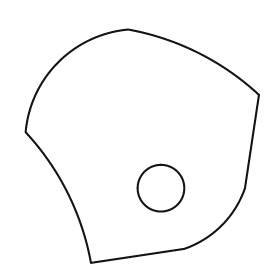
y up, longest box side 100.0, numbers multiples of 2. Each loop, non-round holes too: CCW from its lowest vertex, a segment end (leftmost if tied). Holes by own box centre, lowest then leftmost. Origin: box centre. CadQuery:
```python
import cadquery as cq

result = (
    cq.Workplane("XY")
    .moveTo(-22.0, -50.0)
    .lineTo(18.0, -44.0)
    .threePointArc((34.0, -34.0), (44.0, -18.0))
    .lineTo(50.0, 22.0)
    .threePointArc((24.0, 40.0), (-6.0, 50.0))
    .threePointArc((-36.0, 36.0), (-50.0, 6.0))
    .threePointArc((-32.0, -20.0), (-22.0, -50.0))
    .close()
    .moveTo(8.0, -18.0)
    .circle(10.0)
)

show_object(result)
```